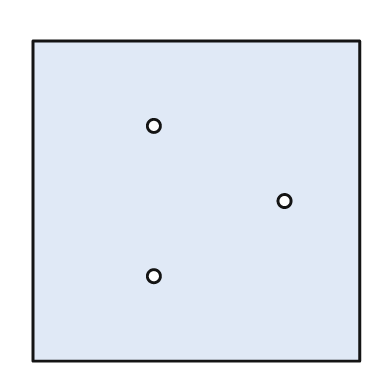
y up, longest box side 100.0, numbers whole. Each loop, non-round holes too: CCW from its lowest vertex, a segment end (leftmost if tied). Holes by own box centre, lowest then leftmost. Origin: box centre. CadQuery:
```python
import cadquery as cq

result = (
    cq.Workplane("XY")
    .moveTo(-50.0, -49.0)
    .lineTo(50.0, -49.0)
    .lineTo(50.0, 49.0)
    .lineTo(-50.0, 49.0)
    .close()
    .moveTo(-13.0, -23.0)
    .circle(2.0)
    .moveTo(27.0, 0.0)
    .circle(2.0)
    .moveTo(-13.0, 23.0)
    .circle(2.0)
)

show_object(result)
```